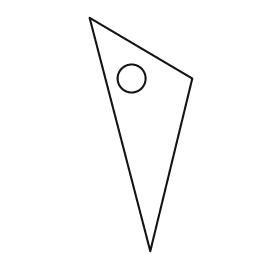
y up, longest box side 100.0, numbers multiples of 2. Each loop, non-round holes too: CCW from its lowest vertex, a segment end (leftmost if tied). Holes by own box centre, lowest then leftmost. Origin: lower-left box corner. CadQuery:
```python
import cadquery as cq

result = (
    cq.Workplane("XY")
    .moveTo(26.0, 0.0)
    .lineTo(44.0, 74.0)
    .lineTo(0.0, 100.0)
    .close()
    .moveTo(18.0, 74.0)
    .circle(6.0)
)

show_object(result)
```